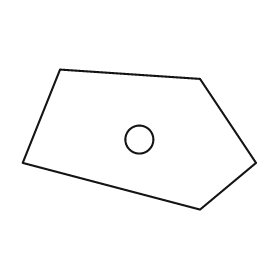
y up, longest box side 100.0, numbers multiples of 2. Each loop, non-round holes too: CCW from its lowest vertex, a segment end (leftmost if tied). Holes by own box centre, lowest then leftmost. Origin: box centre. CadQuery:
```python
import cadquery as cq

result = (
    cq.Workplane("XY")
    .moveTo(26.0, -30.0)
    .lineTo(50.0, -10.0)
    .lineTo(26.0, 26.0)
    .lineTo(-34.0, 30.0)
    .lineTo(-50.0, -10.0)
    .close()
    .moveTo(0.0, 0.0)
    .circle(6.0)
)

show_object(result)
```